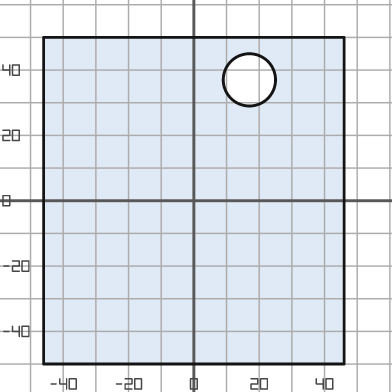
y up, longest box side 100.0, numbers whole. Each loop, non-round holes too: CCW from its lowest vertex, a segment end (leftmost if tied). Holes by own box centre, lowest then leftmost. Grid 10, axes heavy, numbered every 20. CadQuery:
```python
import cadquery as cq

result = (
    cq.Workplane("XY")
    .moveTo(-46.0, -50.0)
    .lineTo(46.0, -50.0)
    .lineTo(46.0, 50.0)
    .lineTo(-46.0, 50.0)
    .close()
    .moveTo(17.0, 37.0)
    .circle(8.0)
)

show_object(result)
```